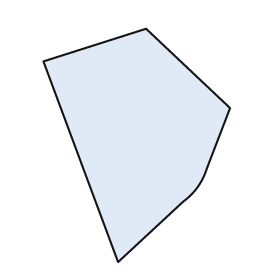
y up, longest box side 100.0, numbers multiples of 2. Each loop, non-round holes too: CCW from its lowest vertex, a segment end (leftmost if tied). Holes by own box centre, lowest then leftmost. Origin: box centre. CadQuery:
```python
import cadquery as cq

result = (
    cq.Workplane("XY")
    .moveTo(-8.0, -50.0)
    .lineTo(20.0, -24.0)
    .threePointArc((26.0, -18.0), (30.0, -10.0))
    .lineTo(40.0, 16.0)
    .lineTo(4.0, 50.0)
    .lineTo(-40.0, 36.0)
    .close()
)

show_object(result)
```